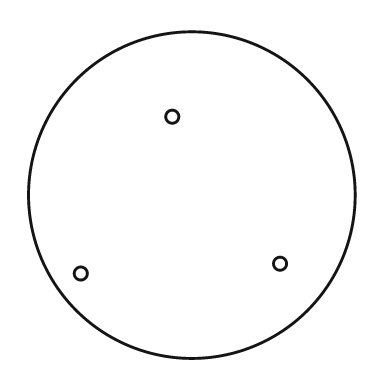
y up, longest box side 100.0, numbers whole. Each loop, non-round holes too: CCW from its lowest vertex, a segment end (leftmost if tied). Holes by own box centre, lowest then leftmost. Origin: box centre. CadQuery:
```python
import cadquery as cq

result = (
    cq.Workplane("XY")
    .moveTo(0.0, 0.0)
    .circle(50.0)
    .moveTo(-34.0, -24.0)
    .circle(2.0)
    .moveTo(27.0, -21.0)
    .circle(2.0)
    .moveTo(-6.0, 24.0)
    .circle(2.0)
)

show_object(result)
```